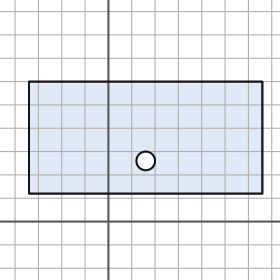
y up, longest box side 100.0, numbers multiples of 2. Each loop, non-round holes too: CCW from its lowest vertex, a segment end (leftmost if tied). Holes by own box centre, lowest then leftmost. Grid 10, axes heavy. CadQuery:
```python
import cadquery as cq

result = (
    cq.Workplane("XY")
    .moveTo(-34.0, 12.0)
    .lineTo(66.0, 12.0)
    .lineTo(66.0, 60.0)
    .lineTo(-34.0, 60.0)
    .close()
    .moveTo(16.0, 26.0)
    .circle(4.0)
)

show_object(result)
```